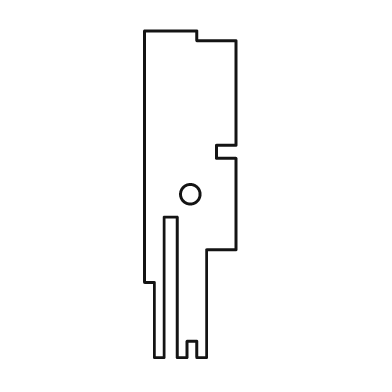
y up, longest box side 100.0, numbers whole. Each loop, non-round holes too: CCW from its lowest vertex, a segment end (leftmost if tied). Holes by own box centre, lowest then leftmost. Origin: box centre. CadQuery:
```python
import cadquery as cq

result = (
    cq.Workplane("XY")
    .moveTo(-11.0, -50.0)
    .lineTo(-8.0, -50.0)
    .lineTo(-8.0, -7.0)
    .lineTo(-4.0, -7.0)
    .lineTo(-4.0, -50.0)
    .lineTo(-1.0, -50.0)
    .lineTo(-1.0, -45.0)
    .lineTo(2.0, -45.0)
    .lineTo(2.0, -50.0)
    .lineTo(5.0, -50.0)
    .lineTo(5.0, -17.0)
    .lineTo(14.0, -17.0)
    .lineTo(14.0, 11.0)
    .lineTo(8.0, 11.0)
    .lineTo(8.0, 15.0)
    .lineTo(14.0, 15.0)
    .lineTo(14.0, 47.0)
    .lineTo(2.0, 47.0)
    .lineTo(2.0, 50.0)
    .lineTo(-14.0, 50.0)
    .lineTo(-14.0, -27.0)
    .lineTo(-11.0, -27.0)
    .close()
    .moveTo(0.0, 0.0)
    .circle(3.0)
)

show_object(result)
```